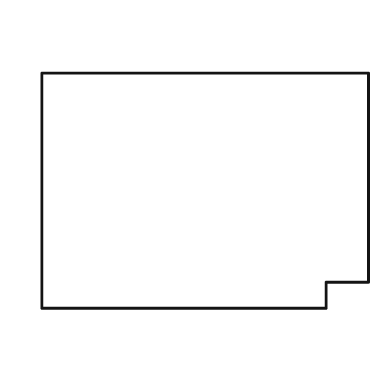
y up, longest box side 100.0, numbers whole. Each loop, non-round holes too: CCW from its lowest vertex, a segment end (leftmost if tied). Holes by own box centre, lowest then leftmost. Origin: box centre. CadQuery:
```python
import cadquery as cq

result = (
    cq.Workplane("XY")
    .moveTo(-50.0, -36.0)
    .lineTo(37.0, -36.0)
    .lineTo(37.0, -28.0)
    .lineTo(50.0, -28.0)
    .lineTo(50.0, 36.0)
    .lineTo(-50.0, 36.0)
    .close()
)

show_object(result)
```